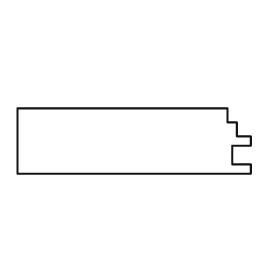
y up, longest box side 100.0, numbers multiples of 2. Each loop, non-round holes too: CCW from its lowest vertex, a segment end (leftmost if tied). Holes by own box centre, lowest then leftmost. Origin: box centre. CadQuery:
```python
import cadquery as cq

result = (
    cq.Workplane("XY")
    .moveTo(-50.0, -14.0)
    .lineTo(50.0, -14.0)
    .lineTo(50.0, -10.0)
    .lineTo(42.0, -10.0)
    .lineTo(42.0, -2.0)
    .lineTo(50.0, -2.0)
    .lineTo(50.0, 2.0)
    .lineTo(44.0, 2.0)
    .lineTo(44.0, 8.0)
    .lineTo(40.0, 8.0)
    .lineTo(40.0, 14.0)
    .lineTo(-50.0, 14.0)
    .close()
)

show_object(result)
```